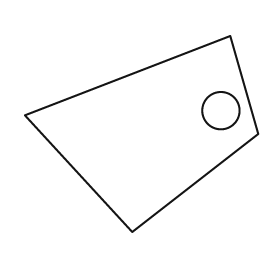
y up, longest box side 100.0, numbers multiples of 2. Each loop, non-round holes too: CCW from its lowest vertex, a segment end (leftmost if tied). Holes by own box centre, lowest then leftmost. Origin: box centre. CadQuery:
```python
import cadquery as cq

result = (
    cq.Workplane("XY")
    .moveTo(-4.0, -42.0)
    .lineTo(50.0, 0.0)
    .lineTo(38.0, 42.0)
    .lineTo(-50.0, 8.0)
    .close()
    .moveTo(34.0, 10.0)
    .circle(8.0)
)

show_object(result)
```